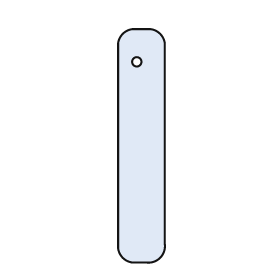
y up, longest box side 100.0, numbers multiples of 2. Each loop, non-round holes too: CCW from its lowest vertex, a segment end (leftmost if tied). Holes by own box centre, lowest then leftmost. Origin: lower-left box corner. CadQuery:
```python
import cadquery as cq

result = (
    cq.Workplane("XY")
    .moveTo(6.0, 0.0)
    .lineTo(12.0, 0.0)
    .threePointArc((18.0, 2.0), (20.0, 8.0))
    .lineTo(20.0, 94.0)
    .threePointArc((18.0, 98.0), (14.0, 100.0))
    .lineTo(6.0, 100.0)
    .threePointArc((2.0, 98.0), (0.0, 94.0))
    .lineTo(0.0, 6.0)
    .threePointArc((2.0, 2.0), (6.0, 0.0))
    .close()
    .moveTo(8.0, 86.0)
    .circle(2.0)
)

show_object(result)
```